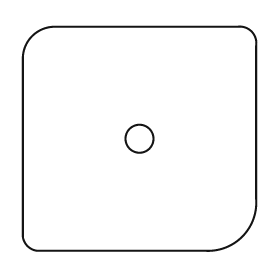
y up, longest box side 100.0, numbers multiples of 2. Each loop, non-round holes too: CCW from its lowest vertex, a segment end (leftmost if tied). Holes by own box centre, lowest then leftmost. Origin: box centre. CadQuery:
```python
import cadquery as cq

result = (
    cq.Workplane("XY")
    .moveTo(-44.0, -48.0)
    .lineTo(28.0, -48.0)
    .threePointArc((44.0, -42.0), (50.0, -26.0))
    .lineTo(50.0, 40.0)
    .threePointArc((48.0, 46.0), (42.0, 48.0))
    .lineTo(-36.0, 48.0)
    .threePointArc((-46.0, 44.0), (-50.0, 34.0))
    .lineTo(-50.0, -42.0)
    .threePointArc((-48.0, -46.0), (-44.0, -48.0))
    .close()
    .moveTo(0.0, 0.0)
    .circle(6.0)
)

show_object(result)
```